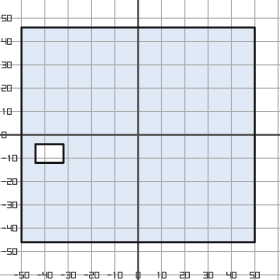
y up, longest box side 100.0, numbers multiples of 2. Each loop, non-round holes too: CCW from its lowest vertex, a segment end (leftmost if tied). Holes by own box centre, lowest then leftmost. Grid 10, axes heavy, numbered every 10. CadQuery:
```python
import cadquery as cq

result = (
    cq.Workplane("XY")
    .moveTo(-50.0, -46.0)
    .lineTo(50.0, -46.0)
    .lineTo(50.0, 46.0)
    .lineTo(-50.0, 46.0)
    .close()
    .moveTo(-44.0, -12.0)
    .lineTo(-32.0, -12.0)
    .lineTo(-32.0, -4.0)
    .lineTo(-44.0, -4.0)
    .close()
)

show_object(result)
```